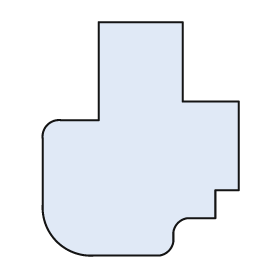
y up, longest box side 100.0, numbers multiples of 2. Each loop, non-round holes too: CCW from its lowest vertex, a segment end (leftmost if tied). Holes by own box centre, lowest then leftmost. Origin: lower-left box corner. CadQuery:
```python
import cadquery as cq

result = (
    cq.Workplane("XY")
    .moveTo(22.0, 0.0)
    .lineTo(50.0, 0.0)
    .threePointArc((54.0, 2.0), (56.0, 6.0))
    .lineTo(56.0, 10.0)
    .threePointArc((58.0, 14.0), (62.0, 16.0))
    .lineTo(74.0, 16.0)
    .lineTo(74.0, 28.0)
    .lineTo(84.0, 28.0)
    .lineTo(84.0, 66.0)
    .lineTo(60.0, 66.0)
    .lineTo(60.0, 100.0)
    .lineTo(24.0, 100.0)
    .lineTo(24.0, 58.0)
    .lineTo(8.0, 58.0)
    .threePointArc((2.0, 56.0), (0.0, 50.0))
    .lineTo(0.0, 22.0)
    .threePointArc((6.0, 6.0), (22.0, 0.0))
    .close()
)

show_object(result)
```